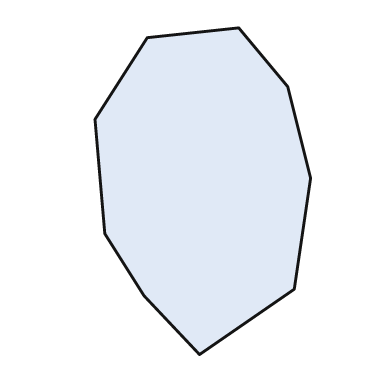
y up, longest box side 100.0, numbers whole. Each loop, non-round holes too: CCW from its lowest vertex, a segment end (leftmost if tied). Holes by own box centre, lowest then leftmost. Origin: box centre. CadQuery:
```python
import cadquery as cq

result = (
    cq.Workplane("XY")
    .moveTo(-1.0, -50.0)
    .lineTo(28.0, -30.0)
    .lineTo(33.0, 4.0)
    .lineTo(26.0, 32.0)
    .lineTo(11.0, 50.0)
    .lineTo(-17.0, 47.0)
    .lineTo(-33.0, 22.0)
    .lineTo(-30.0, -13.0)
    .lineTo(-18.0, -32.0)
    .close()
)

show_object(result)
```